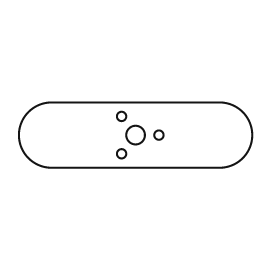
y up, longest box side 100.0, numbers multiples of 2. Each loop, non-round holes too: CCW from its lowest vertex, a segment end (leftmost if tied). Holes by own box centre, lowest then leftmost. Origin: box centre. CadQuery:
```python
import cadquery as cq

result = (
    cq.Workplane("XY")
    .moveTo(-36.0, -14.0)
    .lineTo(36.0, -14.0)
    .threePointArc((50.0, 0.0), (36.0, 14.0))
    .lineTo(-36.0, 14.0)
    .threePointArc((-50.0, 0.0), (-36.0, -14.0))
    .close()
    .moveTo(-6.0, -8.0)
    .circle(2.0)
    .moveTo(0.0, 0.0)
    .circle(4.0)
    .moveTo(10.0, 0.0)
    .circle(2.0)
    .moveTo(-6.0, 8.0)
    .circle(2.0)
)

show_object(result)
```